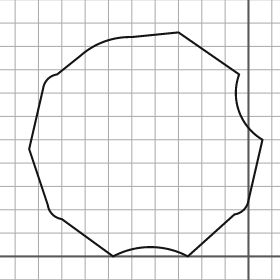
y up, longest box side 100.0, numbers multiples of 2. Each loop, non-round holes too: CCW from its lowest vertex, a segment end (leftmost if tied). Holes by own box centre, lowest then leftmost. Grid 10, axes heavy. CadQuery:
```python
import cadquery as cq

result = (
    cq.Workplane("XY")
    .moveTo(-58.0, 0.0)
    .threePointArc((-42.0, 4.0), (-26.0, 0.0))
    .lineTo(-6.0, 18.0)
    .threePointArc((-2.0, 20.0), (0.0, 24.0))
    .lineTo(6.0, 50.0)
    .threePointArc((-4.0, 62.0), (-4.0, 78.0))
    .lineTo(-30.0, 96.0)
    .lineTo(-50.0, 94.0)
    .threePointArc((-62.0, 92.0), (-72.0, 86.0))
    .lineTo(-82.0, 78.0)
    .threePointArc((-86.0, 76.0), (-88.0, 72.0))
    .lineTo(-94.0, 46.0)
    .lineTo(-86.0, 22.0)
    .threePointArc((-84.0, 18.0), (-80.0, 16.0))
    .close()
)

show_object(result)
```